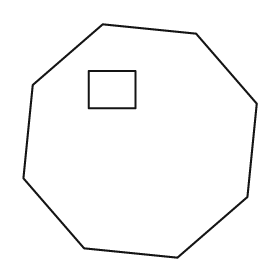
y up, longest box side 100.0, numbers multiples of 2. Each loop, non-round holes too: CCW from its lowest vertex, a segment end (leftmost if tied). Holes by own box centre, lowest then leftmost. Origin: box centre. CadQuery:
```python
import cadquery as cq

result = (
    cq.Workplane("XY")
    .moveTo(16.0, -50.0)
    .lineTo(46.0, -24.0)
    .lineTo(50.0, 16.0)
    .lineTo(24.0, 46.0)
    .lineTo(-16.0, 50.0)
    .lineTo(-46.0, 24.0)
    .lineTo(-50.0, -16.0)
    .lineTo(-24.0, -46.0)
    .close()
    .moveTo(-22.0, 14.0)
    .lineTo(-2.0, 14.0)
    .lineTo(-2.0, 30.0)
    .lineTo(-22.0, 30.0)
    .close()
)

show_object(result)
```